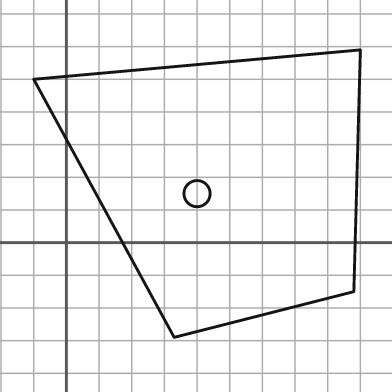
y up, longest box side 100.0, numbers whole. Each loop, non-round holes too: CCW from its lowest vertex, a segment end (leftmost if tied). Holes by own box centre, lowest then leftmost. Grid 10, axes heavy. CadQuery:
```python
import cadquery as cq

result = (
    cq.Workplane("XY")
    .moveTo(33.0, -29.0)
    .lineTo(88.0, -15.0)
    .lineTo(90.0, 59.0)
    .lineTo(-10.0, 50.0)
    .close()
    .moveTo(40.0, 15.0)
    .circle(4.0)
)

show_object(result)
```